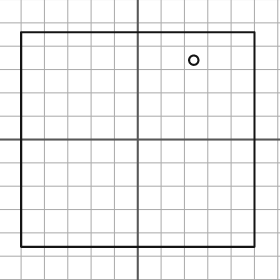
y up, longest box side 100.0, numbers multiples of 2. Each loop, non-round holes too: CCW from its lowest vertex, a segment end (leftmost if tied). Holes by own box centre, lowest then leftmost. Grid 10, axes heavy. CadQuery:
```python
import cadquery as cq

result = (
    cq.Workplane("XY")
    .moveTo(-50.0, -46.0)
    .lineTo(50.0, -46.0)
    .lineTo(50.0, 46.0)
    .lineTo(-50.0, 46.0)
    .close()
    .moveTo(24.0, 34.0)
    .circle(2.0)
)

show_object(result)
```